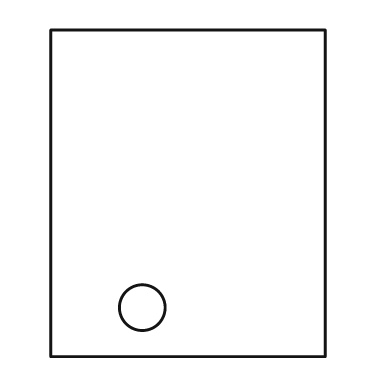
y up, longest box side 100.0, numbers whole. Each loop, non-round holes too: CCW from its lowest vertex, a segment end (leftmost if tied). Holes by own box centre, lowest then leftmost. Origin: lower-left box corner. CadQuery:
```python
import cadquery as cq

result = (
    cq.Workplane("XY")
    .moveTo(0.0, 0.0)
    .lineTo(84.0, 0.0)
    .lineTo(84.0, 100.0)
    .lineTo(0.0, 100.0)
    .close()
    .moveTo(28.0, 15.0)
    .circle(7.0)
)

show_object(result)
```